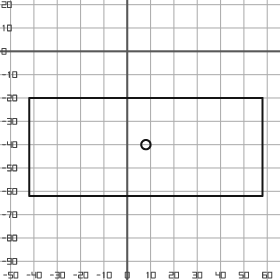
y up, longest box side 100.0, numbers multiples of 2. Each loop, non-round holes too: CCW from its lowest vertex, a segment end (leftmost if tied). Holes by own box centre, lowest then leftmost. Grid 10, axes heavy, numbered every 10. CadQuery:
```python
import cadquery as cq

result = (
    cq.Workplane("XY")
    .moveTo(-42.0, -62.0)
    .lineTo(58.0, -62.0)
    .lineTo(58.0, -20.0)
    .lineTo(-42.0, -20.0)
    .close()
    .moveTo(8.0, -40.0)
    .circle(2.0)
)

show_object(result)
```